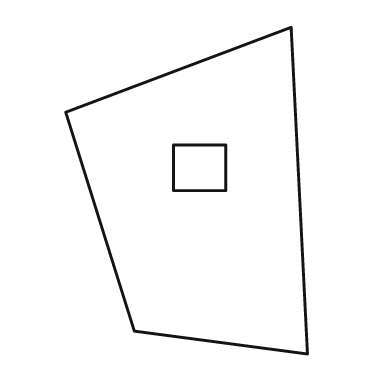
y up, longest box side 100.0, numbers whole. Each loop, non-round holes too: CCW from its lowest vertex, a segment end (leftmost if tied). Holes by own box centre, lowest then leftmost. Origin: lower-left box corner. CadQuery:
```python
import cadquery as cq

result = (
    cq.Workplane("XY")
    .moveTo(74.0, 0.0)
    .lineTo(69.0, 100.0)
    .lineTo(0.0, 74.0)
    .lineTo(21.0, 7.0)
    .close()
    .moveTo(33.0, 50.0)
    .lineTo(49.0, 50.0)
    .lineTo(49.0, 64.0)
    .lineTo(33.0, 64.0)
    .close()
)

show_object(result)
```